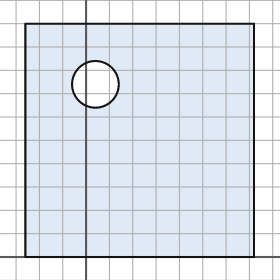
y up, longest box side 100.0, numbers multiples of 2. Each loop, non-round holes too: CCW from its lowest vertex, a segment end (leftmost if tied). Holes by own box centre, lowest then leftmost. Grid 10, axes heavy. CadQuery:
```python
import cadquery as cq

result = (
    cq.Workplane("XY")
    .moveTo(-26.0, 0.0)
    .lineTo(72.0, 0.0)
    .lineTo(72.0, 100.0)
    .lineTo(-26.0, 100.0)
    .close()
    .moveTo(4.0, 74.0)
    .circle(10.0)
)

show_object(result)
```